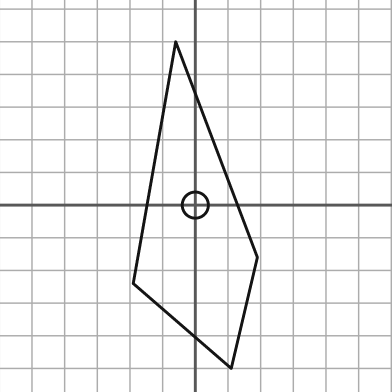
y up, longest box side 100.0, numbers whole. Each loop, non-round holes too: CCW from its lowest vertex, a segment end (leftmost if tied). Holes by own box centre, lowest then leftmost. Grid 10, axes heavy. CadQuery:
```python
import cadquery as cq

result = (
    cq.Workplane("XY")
    .moveTo(11.0, -50.0)
    .lineTo(19.0, -16.0)
    .lineTo(-6.0, 50.0)
    .lineTo(-19.0, -24.0)
    .close()
    .moveTo(0.0, 0.0)
    .circle(4.0)
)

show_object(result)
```